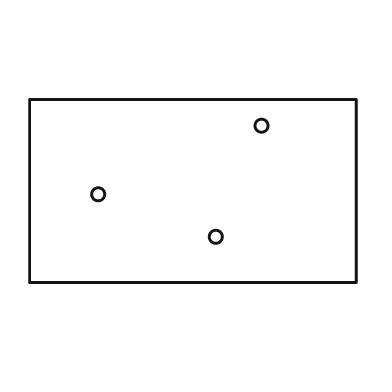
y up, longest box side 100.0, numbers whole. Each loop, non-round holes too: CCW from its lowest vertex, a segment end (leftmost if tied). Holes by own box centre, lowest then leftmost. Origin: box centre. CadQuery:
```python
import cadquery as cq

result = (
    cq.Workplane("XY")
    .moveTo(-50.0, -28.0)
    .lineTo(50.0, -28.0)
    .lineTo(50.0, 28.0)
    .lineTo(-50.0, 28.0)
    .close()
    .moveTo(7.0, -14.0)
    .circle(2.0)
    .moveTo(-29.0, -1.0)
    .circle(2.0)
    .moveTo(21.0, 20.0)
    .circle(2.0)
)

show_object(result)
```